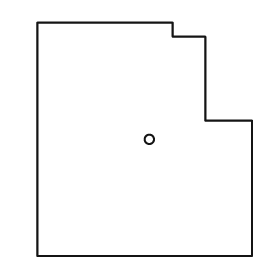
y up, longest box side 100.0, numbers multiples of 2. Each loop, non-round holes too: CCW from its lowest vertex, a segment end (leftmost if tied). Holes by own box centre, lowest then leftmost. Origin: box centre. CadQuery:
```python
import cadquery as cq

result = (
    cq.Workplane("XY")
    .moveTo(-46.0, -50.0)
    .lineTo(46.0, -50.0)
    .lineTo(46.0, 8.0)
    .lineTo(26.0, 8.0)
    .lineTo(26.0, 44.0)
    .lineTo(12.0, 44.0)
    .lineTo(12.0, 50.0)
    .lineTo(-46.0, 50.0)
    .close()
    .moveTo(2.0, 0.0)
    .circle(2.0)
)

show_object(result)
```